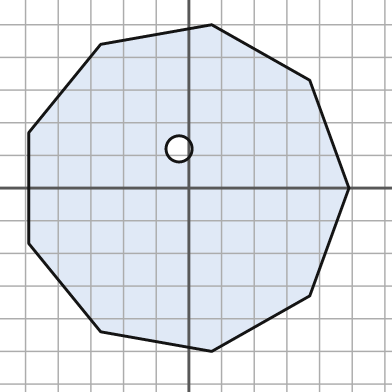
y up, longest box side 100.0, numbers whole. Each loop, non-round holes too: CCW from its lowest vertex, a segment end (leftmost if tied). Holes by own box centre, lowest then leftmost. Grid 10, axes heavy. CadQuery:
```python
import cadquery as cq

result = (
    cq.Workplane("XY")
    .moveTo(7.0, -50.0)
    .lineTo(37.0, -33.0)
    .lineTo(49.0, 0.0)
    .lineTo(37.0, 33.0)
    .lineTo(7.0, 50.0)
    .lineTo(-27.0, 44.0)
    .lineTo(-49.0, 17.0)
    .lineTo(-49.0, -17.0)
    .lineTo(-27.0, -44.0)
    .close()
    .moveTo(-3.0, 12.0)
    .circle(4.0)
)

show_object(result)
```